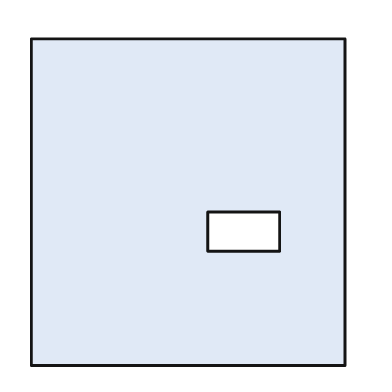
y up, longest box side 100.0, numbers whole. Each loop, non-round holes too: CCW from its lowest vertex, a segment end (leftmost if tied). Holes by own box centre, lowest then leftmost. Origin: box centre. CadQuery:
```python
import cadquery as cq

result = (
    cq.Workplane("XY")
    .moveTo(-48.0, -50.0)
    .lineTo(48.0, -50.0)
    .lineTo(48.0, 50.0)
    .lineTo(-48.0, 50.0)
    .close()
    .moveTo(6.0, -15.0)
    .lineTo(28.0, -15.0)
    .lineTo(28.0, -3.0)
    .lineTo(6.0, -3.0)
    .close()
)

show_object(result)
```